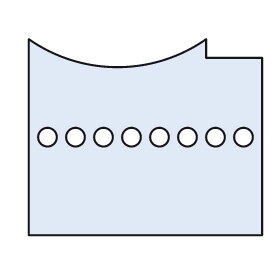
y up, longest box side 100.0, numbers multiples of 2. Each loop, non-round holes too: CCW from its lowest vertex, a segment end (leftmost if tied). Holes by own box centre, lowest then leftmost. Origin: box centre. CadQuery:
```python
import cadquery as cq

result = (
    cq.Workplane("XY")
    .moveTo(-50.0, -42.0)
    .lineTo(50.0, -42.0)
    .lineTo(50.0, 34.0)
    .lineTo(26.0, 34.0)
    .lineTo(26.0, 42.0)
    .threePointArc((-12.0, 30.0), (-50.0, 42.0))
    .close()
    .moveTo(-42.0, 0.0)
    .circle(4.0)
    .moveTo(-30.0, 0.0)
    .circle(4.0)
    .moveTo(-18.0, 0.0)
    .circle(4.0)
    .moveTo(-6.0, 0.0)
    .circle(4.0)
    .moveTo(6.0, 0.0)
    .circle(4.0)
    .moveTo(18.0, 0.0)
    .circle(4.0)
    .moveTo(30.0, 0.0)
    .circle(4.0)
    .moveTo(42.0, 0.0)
    .circle(4.0)
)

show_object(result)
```